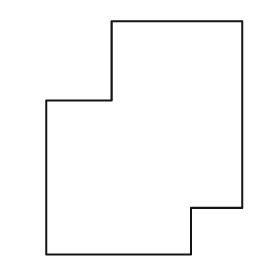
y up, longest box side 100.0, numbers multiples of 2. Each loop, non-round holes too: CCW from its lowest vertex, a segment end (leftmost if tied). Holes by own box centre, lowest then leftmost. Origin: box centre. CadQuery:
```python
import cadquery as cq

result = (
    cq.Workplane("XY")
    .moveTo(-42.0, -50.0)
    .lineTo(20.0, -50.0)
    .lineTo(20.0, -30.0)
    .lineTo(42.0, -30.0)
    .lineTo(42.0, 50.0)
    .lineTo(-14.0, 50.0)
    .lineTo(-14.0, 16.0)
    .lineTo(-42.0, 16.0)
    .close()
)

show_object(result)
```